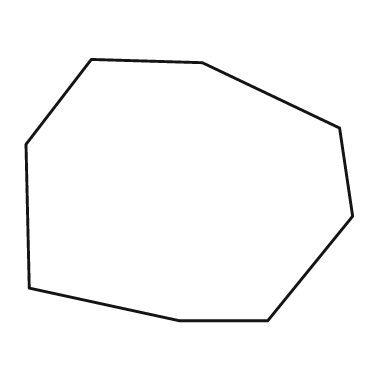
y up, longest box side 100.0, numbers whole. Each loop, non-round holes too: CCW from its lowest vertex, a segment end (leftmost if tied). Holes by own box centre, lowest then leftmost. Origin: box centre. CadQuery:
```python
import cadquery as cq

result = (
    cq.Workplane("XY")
    .moveTo(-3.0, -40.0)
    .lineTo(24.0, -40.0)
    .lineTo(50.0, -8.0)
    .lineTo(46.0, 19.0)
    .lineTo(4.0, 39.0)
    .lineTo(-30.0, 40.0)
    .lineTo(-50.0, 14.0)
    .lineTo(-49.0, -30.0)
    .close()
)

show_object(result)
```